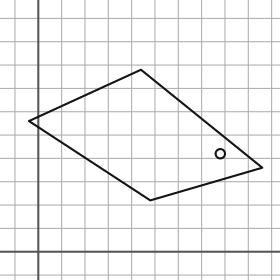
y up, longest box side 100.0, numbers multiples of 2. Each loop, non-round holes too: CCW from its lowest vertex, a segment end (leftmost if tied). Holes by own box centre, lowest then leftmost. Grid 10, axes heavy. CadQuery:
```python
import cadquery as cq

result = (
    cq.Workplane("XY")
    .moveTo(48.0, 22.0)
    .lineTo(96.0, 36.0)
    .lineTo(44.0, 78.0)
    .lineTo(-4.0, 56.0)
    .close()
    .moveTo(78.0, 42.0)
    .circle(2.0)
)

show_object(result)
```